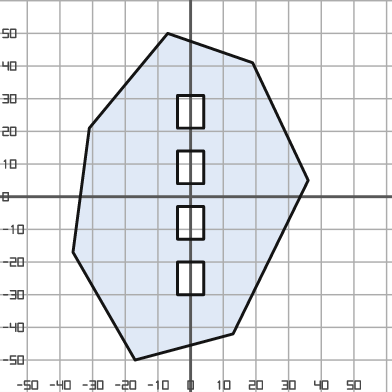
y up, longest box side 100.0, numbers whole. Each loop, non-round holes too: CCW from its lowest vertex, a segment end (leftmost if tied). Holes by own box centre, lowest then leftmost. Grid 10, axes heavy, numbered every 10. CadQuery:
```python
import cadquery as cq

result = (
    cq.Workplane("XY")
    .moveTo(-17.0, -50.0)
    .lineTo(13.0, -42.0)
    .lineTo(36.0, 5.0)
    .lineTo(19.0, 41.0)
    .lineTo(-7.0, 50.0)
    .lineTo(-31.0, 21.0)
    .lineTo(-36.0, -17.0)
    .close()
    .moveTo(-4.0, -30.0)
    .lineTo(4.0, -30.0)
    .lineTo(4.0, -20.0)
    .lineTo(-4.0, -20.0)
    .close()
    .moveTo(-4.0, -13.0)
    .lineTo(4.0, -13.0)
    .lineTo(4.0, -3.0)
    .lineTo(-4.0, -3.0)
    .close()
    .moveTo(-4.0, 4.0)
    .lineTo(4.0, 4.0)
    .lineTo(4.0, 14.0)
    .lineTo(-4.0, 14.0)
    .close()
    .moveTo(-4.0, 21.0)
    .lineTo(4.0, 21.0)
    .lineTo(4.0, 31.0)
    .lineTo(-4.0, 31.0)
    .close()
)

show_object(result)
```